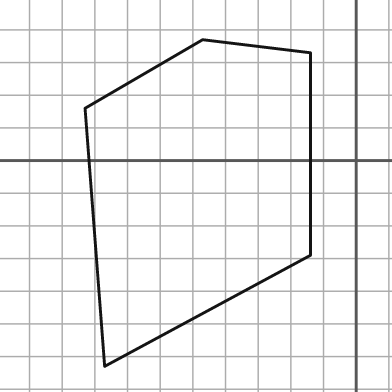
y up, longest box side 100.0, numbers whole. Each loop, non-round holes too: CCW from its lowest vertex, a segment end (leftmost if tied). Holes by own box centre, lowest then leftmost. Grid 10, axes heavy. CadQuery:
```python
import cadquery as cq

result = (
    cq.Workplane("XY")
    .moveTo(-77.0, -63.0)
    .lineTo(-14.0, -29.0)
    .lineTo(-14.0, 33.0)
    .lineTo(-47.0, 37.0)
    .lineTo(-83.0, 16.0)
    .close()
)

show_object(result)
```